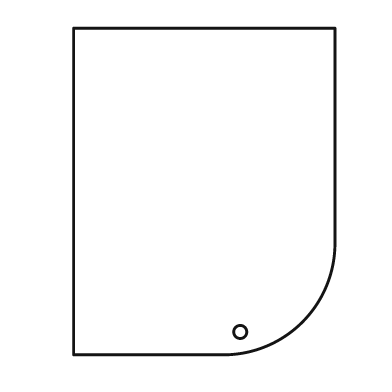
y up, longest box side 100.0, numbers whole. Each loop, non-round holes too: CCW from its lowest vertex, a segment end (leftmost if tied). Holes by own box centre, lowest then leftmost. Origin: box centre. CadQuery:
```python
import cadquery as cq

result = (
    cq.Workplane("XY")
    .moveTo(-40.0, -50.0)
    .lineTo(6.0, -50.0)
    .threePointArc((30.0, -40.0), (40.0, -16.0))
    .lineTo(40.0, 50.0)
    .lineTo(-40.0, 50.0)
    .close()
    .moveTo(11.0, -43.0)
    .circle(2.0)
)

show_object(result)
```